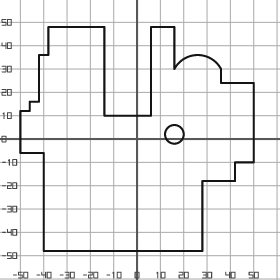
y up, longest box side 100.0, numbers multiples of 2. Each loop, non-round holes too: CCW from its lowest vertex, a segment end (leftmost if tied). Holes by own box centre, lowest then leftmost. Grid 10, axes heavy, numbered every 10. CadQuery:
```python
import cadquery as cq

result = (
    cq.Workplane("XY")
    .moveTo(-40.0, -48.0)
    .lineTo(28.0, -48.0)
    .lineTo(28.0, -18.0)
    .lineTo(42.0, -18.0)
    .lineTo(42.0, -10.0)
    .lineTo(50.0, -10.0)
    .lineTo(50.0, 24.0)
    .lineTo(36.0, 24.0)
    .lineTo(36.0, 30.0)
    .threePointArc((26.0, 36.0), (16.0, 30.0))
    .lineTo(16.0, 48.0)
    .lineTo(6.0, 48.0)
    .lineTo(6.0, 10.0)
    .lineTo(-14.0, 10.0)
    .lineTo(-14.0, 48.0)
    .lineTo(-38.0, 48.0)
    .lineTo(-38.0, 36.0)
    .lineTo(-42.0, 36.0)
    .lineTo(-42.0, 16.0)
    .lineTo(-46.0, 16.0)
    .lineTo(-46.0, 12.0)
    .lineTo(-50.0, 12.0)
    .lineTo(-50.0, -6.0)
    .lineTo(-40.0, -6.0)
    .close()
    .moveTo(16.0, 2.0)
    .circle(4.0)
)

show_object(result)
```